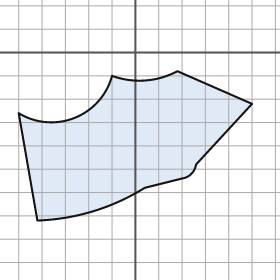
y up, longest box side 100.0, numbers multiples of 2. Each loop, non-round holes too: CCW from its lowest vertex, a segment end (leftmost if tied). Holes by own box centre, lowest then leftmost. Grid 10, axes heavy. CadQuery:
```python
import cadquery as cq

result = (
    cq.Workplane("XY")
    .moveTo(-42.0, -72.0)
    .threePointArc((-18.0, -68.0), (4.0, -58.0))
    .lineTo(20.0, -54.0)
    .threePointArc((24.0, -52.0), (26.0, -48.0))
    .lineTo(50.0, -22.0)
    .lineTo(18.0, -8.0)
    .threePointArc((4.0, -12.0), (-10.0, -10.0))
    .threePointArc((-26.0, -28.0), (-50.0, -26.0))
    .close()
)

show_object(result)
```